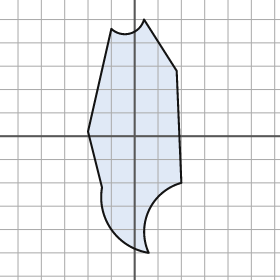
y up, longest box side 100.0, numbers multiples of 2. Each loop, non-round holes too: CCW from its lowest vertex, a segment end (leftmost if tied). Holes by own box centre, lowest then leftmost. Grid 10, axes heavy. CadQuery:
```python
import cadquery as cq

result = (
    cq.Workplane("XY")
    .moveTo(6.0, -50.0)
    .threePointArc((6.0, -32.0), (20.0, -20.0))
    .lineTo(18.0, 28.0)
    .lineTo(4.0, 50.0)
    .threePointArc((-2.0, 44.0), (-10.0, 46.0))
    .lineTo(-20.0, 2.0)
    .lineTo(-14.0, -22.0)
    .threePointArc((-10.0, -40.0), (6.0, -50.0))
    .close()
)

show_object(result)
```